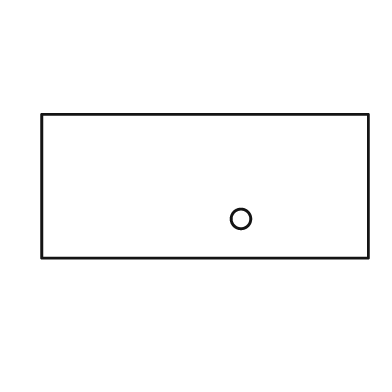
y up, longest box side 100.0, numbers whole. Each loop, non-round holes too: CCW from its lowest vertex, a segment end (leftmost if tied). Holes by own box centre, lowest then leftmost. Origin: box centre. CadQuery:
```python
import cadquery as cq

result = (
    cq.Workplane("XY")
    .moveTo(-50.0, -22.0)
    .lineTo(50.0, -22.0)
    .lineTo(50.0, 22.0)
    .lineTo(-50.0, 22.0)
    .close()
    .moveTo(11.0, -10.0)
    .circle(3.0)
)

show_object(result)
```